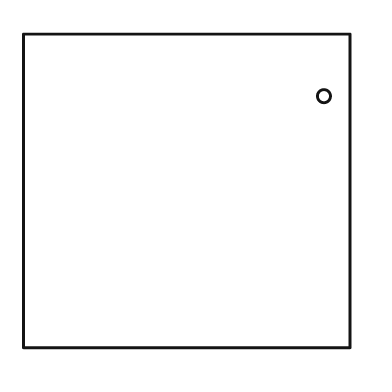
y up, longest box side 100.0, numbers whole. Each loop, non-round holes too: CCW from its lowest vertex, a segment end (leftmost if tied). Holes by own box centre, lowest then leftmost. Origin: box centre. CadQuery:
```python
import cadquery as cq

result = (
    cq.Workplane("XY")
    .moveTo(-50.0, -48.0)
    .lineTo(50.0, -48.0)
    .lineTo(50.0, 48.0)
    .lineTo(-50.0, 48.0)
    .close()
    .moveTo(42.0, 29.0)
    .circle(2.0)
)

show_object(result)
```